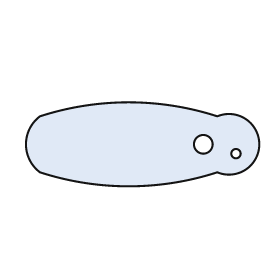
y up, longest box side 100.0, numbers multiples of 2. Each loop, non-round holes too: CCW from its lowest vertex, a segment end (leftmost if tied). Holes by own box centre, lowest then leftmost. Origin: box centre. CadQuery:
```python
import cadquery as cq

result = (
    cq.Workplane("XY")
    .moveTo(-44.0, -12.0)
    .threePointArc((-6.0, -18.0), (32.0, -12.0))
    .threePointArc((50.0, 0.0), (32.0, 12.0))
    .threePointArc((-6.0, 18.0), (-44.0, 12.0))
    .threePointArc((-50.0, 0.0), (-44.0, -12.0))
    .close()
    .moveTo(40.0, -4.0)
    .circle(2.0)
    .moveTo(26.0, 0.0)
    .circle(4.0)
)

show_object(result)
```